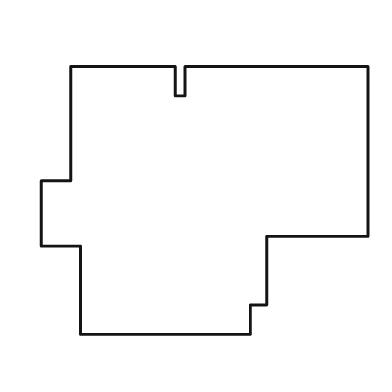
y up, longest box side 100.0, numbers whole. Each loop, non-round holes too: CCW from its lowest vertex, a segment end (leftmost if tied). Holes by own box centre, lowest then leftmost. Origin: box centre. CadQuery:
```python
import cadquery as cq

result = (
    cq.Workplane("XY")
    .moveTo(-38.0, -41.0)
    .lineTo(14.0, -41.0)
    .lineTo(14.0, -32.0)
    .lineTo(19.0, -32.0)
    .lineTo(19.0, -11.0)
    .lineTo(50.0, -11.0)
    .lineTo(50.0, 41.0)
    .lineTo(-6.0, 41.0)
    .lineTo(-6.0, 32.0)
    .lineTo(-9.0, 32.0)
    .lineTo(-9.0, 41.0)
    .lineTo(-41.0, 41.0)
    .lineTo(-41.0, 6.0)
    .lineTo(-50.0, 6.0)
    .lineTo(-50.0, -14.0)
    .lineTo(-38.0, -14.0)
    .close()
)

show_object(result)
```